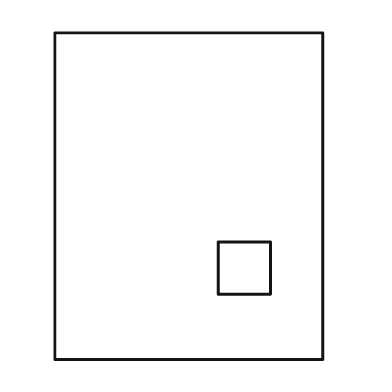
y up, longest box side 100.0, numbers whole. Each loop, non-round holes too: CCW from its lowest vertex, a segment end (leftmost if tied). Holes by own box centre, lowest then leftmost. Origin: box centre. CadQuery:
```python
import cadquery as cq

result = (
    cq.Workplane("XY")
    .moveTo(-41.0, -50.0)
    .lineTo(41.0, -50.0)
    .lineTo(41.0, 50.0)
    .lineTo(-41.0, 50.0)
    .close()
    .moveTo(9.0, -30.0)
    .lineTo(25.0, -30.0)
    .lineTo(25.0, -14.0)
    .lineTo(9.0, -14.0)
    .close()
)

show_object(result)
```